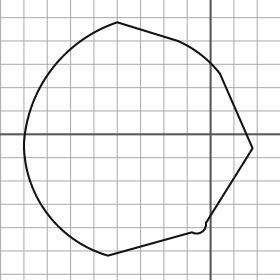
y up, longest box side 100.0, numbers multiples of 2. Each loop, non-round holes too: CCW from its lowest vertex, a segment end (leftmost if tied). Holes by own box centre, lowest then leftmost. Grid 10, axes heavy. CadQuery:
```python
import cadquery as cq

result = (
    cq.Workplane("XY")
    .moveTo(-44.0, -52.0)
    .lineTo(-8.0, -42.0)
    .threePointArc((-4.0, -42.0), (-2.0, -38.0))
    .lineTo(18.0, -6.0)
    .lineTo(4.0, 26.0)
    .threePointArc((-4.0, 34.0), (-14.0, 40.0))
    .lineTo(-40.0, 48.0)
    .threePointArc((-68.0, 28.0), (-80.0, -4.0))
    .threePointArc((-70.0, -34.0), (-44.0, -52.0))
    .close()
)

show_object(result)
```